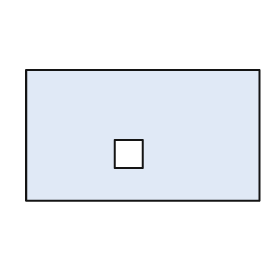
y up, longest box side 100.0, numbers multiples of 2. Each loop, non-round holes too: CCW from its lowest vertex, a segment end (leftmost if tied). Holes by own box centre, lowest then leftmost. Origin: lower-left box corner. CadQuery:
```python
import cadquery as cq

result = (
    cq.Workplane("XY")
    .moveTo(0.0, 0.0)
    .lineTo(100.0, 0.0)
    .lineTo(100.0, 56.0)
    .lineTo(0.0, 56.0)
    .close()
    .moveTo(38.0, 14.0)
    .lineTo(50.0, 14.0)
    .lineTo(50.0, 26.0)
    .lineTo(38.0, 26.0)
    .close()
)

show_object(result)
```